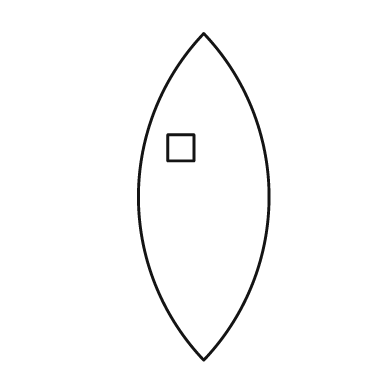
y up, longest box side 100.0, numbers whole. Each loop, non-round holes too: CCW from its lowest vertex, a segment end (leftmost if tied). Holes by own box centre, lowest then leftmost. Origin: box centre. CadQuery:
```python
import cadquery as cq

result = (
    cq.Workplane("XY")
    .moveTo(0.0, -50.0)
    .threePointArc((20.0, 0.0), (0.0, 50.0))
    .threePointArc((-20.0, 0.0), (0.0, -50.0))
    .close()
    .moveTo(-11.0, 11.0)
    .lineTo(-3.0, 11.0)
    .lineTo(-3.0, 19.0)
    .lineTo(-11.0, 19.0)
    .close()
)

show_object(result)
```